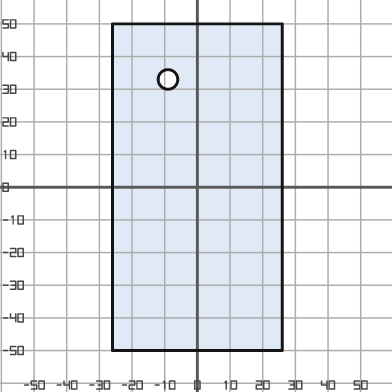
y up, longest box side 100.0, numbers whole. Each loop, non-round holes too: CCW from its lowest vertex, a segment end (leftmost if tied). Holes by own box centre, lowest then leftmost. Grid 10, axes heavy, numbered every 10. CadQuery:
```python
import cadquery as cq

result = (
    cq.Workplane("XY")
    .moveTo(-26.0, -50.0)
    .lineTo(26.0, -50.0)
    .lineTo(26.0, 50.0)
    .lineTo(-26.0, 50.0)
    .close()
    .moveTo(-9.0, 33.0)
    .circle(3.0)
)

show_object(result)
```